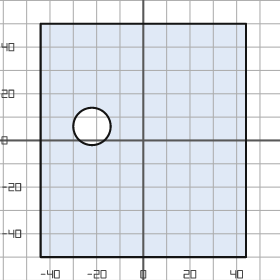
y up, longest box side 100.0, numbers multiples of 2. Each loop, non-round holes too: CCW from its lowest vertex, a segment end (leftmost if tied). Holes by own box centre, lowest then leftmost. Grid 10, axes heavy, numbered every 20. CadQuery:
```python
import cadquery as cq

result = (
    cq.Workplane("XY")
    .moveTo(-44.0, -50.0)
    .lineTo(44.0, -50.0)
    .lineTo(44.0, 50.0)
    .lineTo(-44.0, 50.0)
    .close()
    .moveTo(-22.0, 6.0)
    .circle(8.0)
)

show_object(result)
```